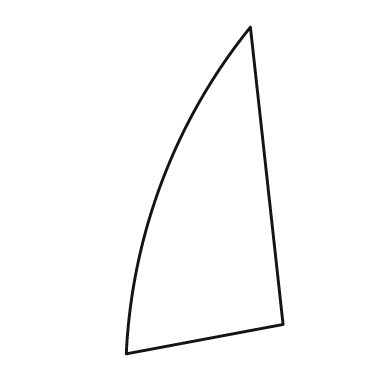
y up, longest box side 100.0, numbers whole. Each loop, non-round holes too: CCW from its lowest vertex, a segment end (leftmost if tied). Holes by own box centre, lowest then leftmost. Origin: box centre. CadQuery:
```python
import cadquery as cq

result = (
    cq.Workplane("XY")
    .moveTo(-24.0, -50.0)
    .lineTo(24.0, -41.0)
    .lineTo(14.0, 50.0)
    .threePointArc((-13.0, 3.0), (-24.0, -50.0))
    .close()
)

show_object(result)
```